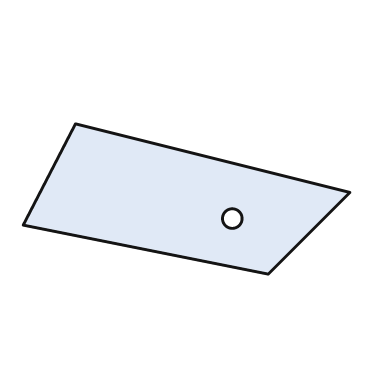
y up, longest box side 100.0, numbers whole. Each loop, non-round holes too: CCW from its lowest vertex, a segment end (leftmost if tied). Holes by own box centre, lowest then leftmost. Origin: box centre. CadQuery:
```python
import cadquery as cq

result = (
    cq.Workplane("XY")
    .moveTo(25.0, -23.0)
    .lineTo(50.0, 2.0)
    .lineTo(-34.0, 23.0)
    .lineTo(-50.0, -8.0)
    .close()
    .moveTo(14.0, -6.0)
    .circle(3.0)
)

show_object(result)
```